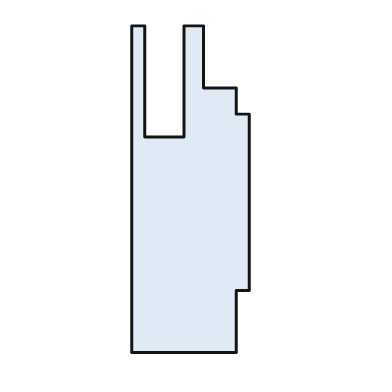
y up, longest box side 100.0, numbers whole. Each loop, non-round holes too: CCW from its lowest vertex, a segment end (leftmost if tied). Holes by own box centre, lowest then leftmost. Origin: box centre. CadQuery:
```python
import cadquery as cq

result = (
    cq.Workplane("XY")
    .moveTo(-18.0, -50.0)
    .lineTo(14.0, -50.0)
    .lineTo(14.0, -31.0)
    .lineTo(18.0, -31.0)
    .lineTo(18.0, 23.0)
    .lineTo(14.0, 23.0)
    .lineTo(14.0, 31.0)
    .lineTo(4.0, 31.0)
    .lineTo(4.0, 50.0)
    .lineTo(-2.0, 50.0)
    .lineTo(-2.0, 16.0)
    .lineTo(-14.0, 16.0)
    .lineTo(-14.0, 50.0)
    .lineTo(-18.0, 50.0)
    .close()
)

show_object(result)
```